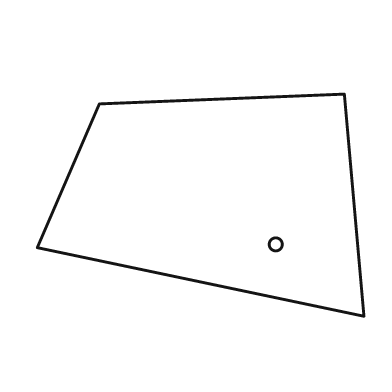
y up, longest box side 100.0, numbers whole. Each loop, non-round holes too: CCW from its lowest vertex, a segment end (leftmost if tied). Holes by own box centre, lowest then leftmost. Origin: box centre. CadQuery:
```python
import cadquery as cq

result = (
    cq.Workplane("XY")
    .moveTo(50.0, -34.0)
    .lineTo(44.0, 34.0)
    .lineTo(-31.0, 31.0)
    .lineTo(-50.0, -13.0)
    .close()
    .moveTo(23.0, -12.0)
    .circle(2.0)
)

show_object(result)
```